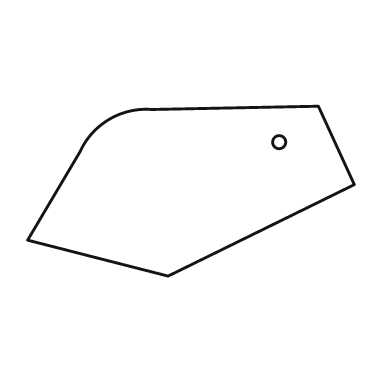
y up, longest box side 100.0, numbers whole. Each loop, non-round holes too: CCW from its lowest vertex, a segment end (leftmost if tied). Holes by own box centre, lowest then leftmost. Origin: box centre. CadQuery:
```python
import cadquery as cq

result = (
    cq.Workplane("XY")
    .moveTo(-7.0, -26.0)
    .lineTo(50.0, 2.0)
    .lineTo(39.0, 26.0)
    .lineTo(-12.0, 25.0)
    .threePointArc((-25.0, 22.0), (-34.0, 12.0))
    .lineTo(-50.0, -15.0)
    .close()
    .moveTo(27.0, 15.0)
    .circle(2.0)
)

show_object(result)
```